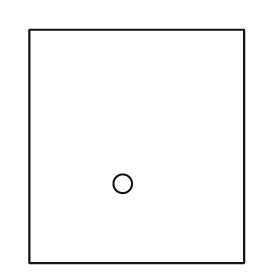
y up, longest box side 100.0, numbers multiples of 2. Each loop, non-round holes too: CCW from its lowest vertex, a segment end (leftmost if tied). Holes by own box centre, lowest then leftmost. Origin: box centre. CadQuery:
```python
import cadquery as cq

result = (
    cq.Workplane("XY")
    .moveTo(-46.0, -50.0)
    .lineTo(46.0, -50.0)
    .lineTo(46.0, 50.0)
    .lineTo(-46.0, 50.0)
    .close()
    .moveTo(-6.0, -16.0)
    .circle(4.0)
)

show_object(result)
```